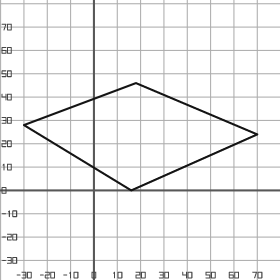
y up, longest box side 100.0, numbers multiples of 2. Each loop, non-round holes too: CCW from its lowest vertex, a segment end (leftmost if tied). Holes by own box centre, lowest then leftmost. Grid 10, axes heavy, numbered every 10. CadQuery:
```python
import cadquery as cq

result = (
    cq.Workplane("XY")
    .moveTo(16.0, 0.0)
    .lineTo(70.0, 24.0)
    .lineTo(18.0, 46.0)
    .lineTo(-30.0, 28.0)
    .close()
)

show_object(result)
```